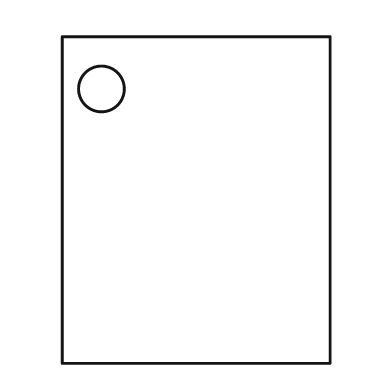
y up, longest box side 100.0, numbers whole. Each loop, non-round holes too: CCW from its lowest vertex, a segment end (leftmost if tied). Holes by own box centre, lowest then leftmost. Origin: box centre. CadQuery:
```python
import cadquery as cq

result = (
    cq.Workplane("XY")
    .moveTo(-41.0, -50.0)
    .lineTo(41.0, -50.0)
    .lineTo(41.0, 50.0)
    .lineTo(-41.0, 50.0)
    .close()
    .moveTo(-29.0, 34.0)
    .circle(7.0)
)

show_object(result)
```